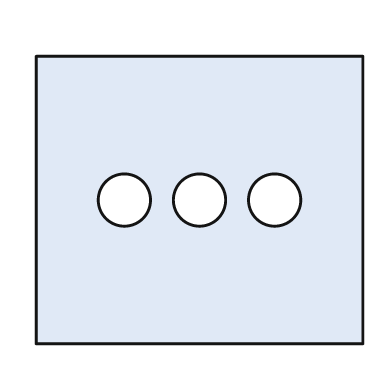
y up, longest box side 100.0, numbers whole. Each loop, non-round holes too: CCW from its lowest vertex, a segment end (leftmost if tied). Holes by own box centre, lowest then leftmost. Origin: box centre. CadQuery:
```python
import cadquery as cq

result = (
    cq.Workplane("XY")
    .moveTo(-50.0, -44.0)
    .lineTo(50.0, -44.0)
    .lineTo(50.0, 44.0)
    .lineTo(-50.0, 44.0)
    .close()
    .moveTo(-23.0, 0.0)
    .circle(8.0)
    .moveTo(0.0, 0.0)
    .circle(8.0)
    .moveTo(23.0, 0.0)
    .circle(8.0)
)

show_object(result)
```